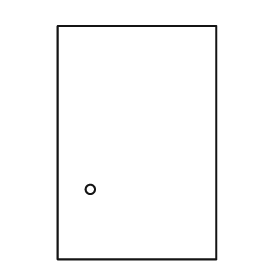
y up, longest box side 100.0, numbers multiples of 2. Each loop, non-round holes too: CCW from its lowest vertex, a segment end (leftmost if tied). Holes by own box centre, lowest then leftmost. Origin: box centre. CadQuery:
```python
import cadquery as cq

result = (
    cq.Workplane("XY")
    .moveTo(-34.0, -50.0)
    .lineTo(34.0, -50.0)
    .lineTo(34.0, 50.0)
    .lineTo(-34.0, 50.0)
    .close()
    .moveTo(-20.0, -20.0)
    .circle(2.0)
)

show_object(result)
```